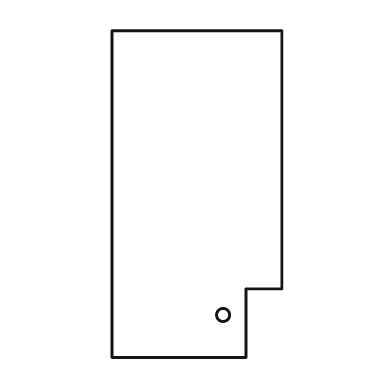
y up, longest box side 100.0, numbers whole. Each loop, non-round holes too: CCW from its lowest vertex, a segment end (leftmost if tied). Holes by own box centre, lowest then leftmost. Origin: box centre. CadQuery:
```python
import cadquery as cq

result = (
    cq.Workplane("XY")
    .moveTo(-26.0, -50.0)
    .lineTo(15.0, -50.0)
    .lineTo(15.0, -29.0)
    .lineTo(26.0, -29.0)
    .lineTo(26.0, 50.0)
    .lineTo(-26.0, 50.0)
    .close()
    .moveTo(8.0, -37.0)
    .circle(2.0)
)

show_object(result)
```